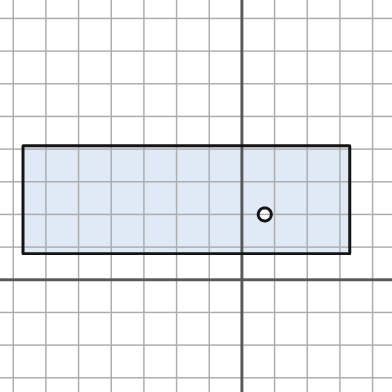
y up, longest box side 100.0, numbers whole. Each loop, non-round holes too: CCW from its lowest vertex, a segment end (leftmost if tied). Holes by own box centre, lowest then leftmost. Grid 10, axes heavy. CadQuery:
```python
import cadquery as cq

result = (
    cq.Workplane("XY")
    .moveTo(-67.0, 8.0)
    .lineTo(33.0, 8.0)
    .lineTo(33.0, 41.0)
    .lineTo(-67.0, 41.0)
    .close()
    .moveTo(7.0, 20.0)
    .circle(2.0)
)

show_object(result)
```